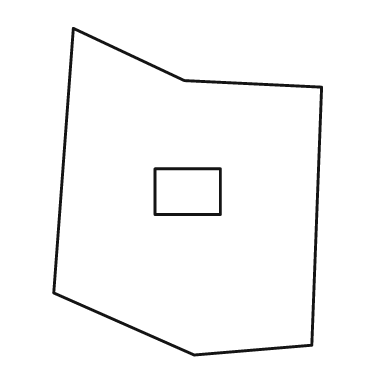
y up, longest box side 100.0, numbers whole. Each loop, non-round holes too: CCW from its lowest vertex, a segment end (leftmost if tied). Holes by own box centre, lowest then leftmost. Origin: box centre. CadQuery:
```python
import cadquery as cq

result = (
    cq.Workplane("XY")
    .moveTo(2.0, -50.0)
    .lineTo(38.0, -47.0)
    .lineTo(41.0, 32.0)
    .lineTo(-1.0, 34.0)
    .lineTo(-35.0, 50.0)
    .lineTo(-41.0, -31.0)
    .close()
    .moveTo(-10.0, -7.0)
    .lineTo(10.0, -7.0)
    .lineTo(10.0, 7.0)
    .lineTo(-10.0, 7.0)
    .close()
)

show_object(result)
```